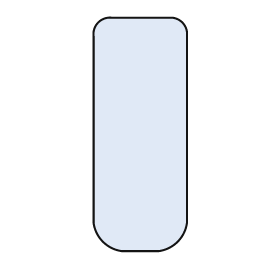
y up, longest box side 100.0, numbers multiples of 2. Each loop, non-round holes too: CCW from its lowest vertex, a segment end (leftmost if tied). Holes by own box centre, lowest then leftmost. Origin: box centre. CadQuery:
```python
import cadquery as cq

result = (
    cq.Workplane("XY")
    .moveTo(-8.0, -50.0)
    .lineTo(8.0, -50.0)
    .threePointArc((16.0, -46.0), (20.0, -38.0))
    .lineTo(20.0, 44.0)
    .threePointArc((18.0, 48.0), (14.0, 50.0))
    .lineTo(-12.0, 50.0)
    .threePointArc((-18.0, 48.0), (-20.0, 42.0))
    .lineTo(-20.0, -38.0)
    .threePointArc((-16.0, -46.0), (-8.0, -50.0))
    .close()
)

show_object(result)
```